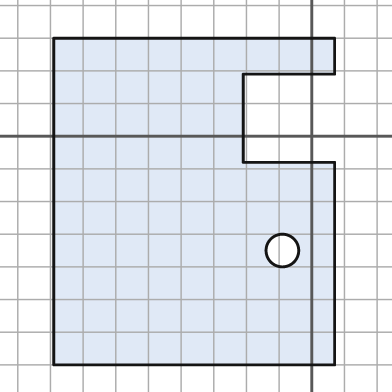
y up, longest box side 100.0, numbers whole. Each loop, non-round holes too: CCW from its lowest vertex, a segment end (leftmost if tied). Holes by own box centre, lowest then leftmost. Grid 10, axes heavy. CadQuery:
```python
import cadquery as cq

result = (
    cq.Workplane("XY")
    .moveTo(-79.0, -70.0)
    .lineTo(7.0, -70.0)
    .lineTo(7.0, -8.0)
    .lineTo(-21.0, -8.0)
    .lineTo(-21.0, 19.0)
    .lineTo(7.0, 19.0)
    .lineTo(7.0, 30.0)
    .lineTo(-79.0, 30.0)
    .close()
    .moveTo(-9.0, -35.0)
    .circle(5.0)
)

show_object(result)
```